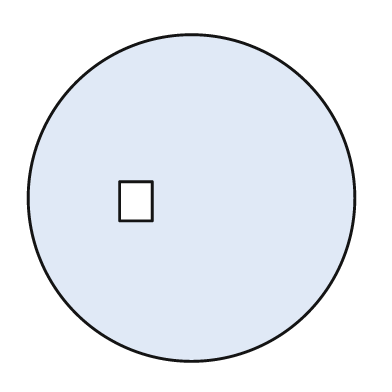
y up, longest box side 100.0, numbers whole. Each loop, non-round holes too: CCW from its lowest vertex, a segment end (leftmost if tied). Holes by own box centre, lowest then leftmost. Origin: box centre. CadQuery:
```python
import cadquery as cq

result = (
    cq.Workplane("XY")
    .moveTo(0.0, 0.0)
    .circle(50.0)
    .moveTo(-22.0, -7.0)
    .lineTo(-12.0, -7.0)
    .lineTo(-12.0, 5.0)
    .lineTo(-22.0, 5.0)
    .close()
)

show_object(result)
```